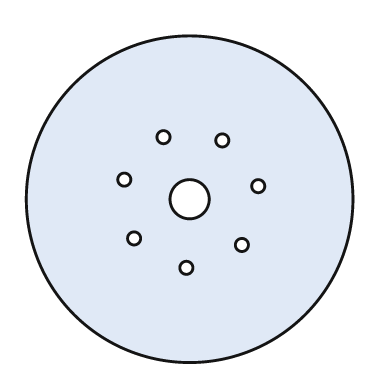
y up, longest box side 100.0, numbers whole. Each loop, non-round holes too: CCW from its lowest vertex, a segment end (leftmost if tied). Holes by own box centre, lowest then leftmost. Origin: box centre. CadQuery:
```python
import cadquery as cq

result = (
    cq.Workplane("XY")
    .moveTo(0.0, 0.0)
    .circle(50.0)
    .moveTo(-1.0, -21.0)
    .circle(2.0)
    .moveTo(16.0, -14.0)
    .circle(2.0)
    .moveTo(-17.0, -12.0)
    .circle(2.0)
    .moveTo(0.0, 0.0)
    .circle(6.0)
    .moveTo(21.0, 4.0)
    .circle(2.0)
    .moveTo(-20.0, 6.0)
    .circle(2.0)
    .moveTo(10.0, 18.0)
    .circle(2.0)
    .moveTo(-8.0, 19.0)
    .circle(2.0)
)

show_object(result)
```